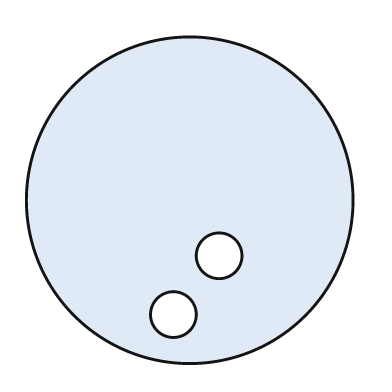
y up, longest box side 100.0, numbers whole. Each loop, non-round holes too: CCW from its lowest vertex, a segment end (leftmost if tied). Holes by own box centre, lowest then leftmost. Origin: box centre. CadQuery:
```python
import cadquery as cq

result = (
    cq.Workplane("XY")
    .moveTo(0.0, 0.0)
    .circle(50.0)
    .moveTo(-5.0, -35.0)
    .circle(7.0)
    .moveTo(9.0, -17.0)
    .circle(7.0)
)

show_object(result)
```